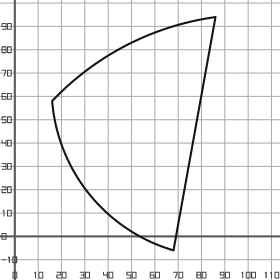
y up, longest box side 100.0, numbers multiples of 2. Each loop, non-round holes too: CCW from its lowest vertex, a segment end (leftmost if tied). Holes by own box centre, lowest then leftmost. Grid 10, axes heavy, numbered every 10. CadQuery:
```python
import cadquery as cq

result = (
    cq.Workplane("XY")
    .moveTo(68.0, -6.0)
    .lineTo(86.0, 94.0)
    .threePointArc((48.0, 82.0), (16.0, 58.0))
    .threePointArc((32.0, 18.0), (68.0, -6.0))
    .close()
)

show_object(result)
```